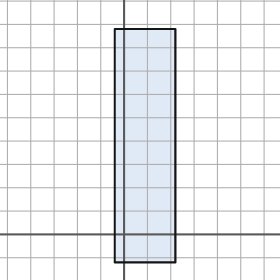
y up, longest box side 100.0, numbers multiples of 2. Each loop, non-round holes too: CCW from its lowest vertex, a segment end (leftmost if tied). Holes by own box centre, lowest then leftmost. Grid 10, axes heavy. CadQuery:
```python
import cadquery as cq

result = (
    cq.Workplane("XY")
    .moveTo(-4.0, -12.0)
    .lineTo(22.0, -12.0)
    .lineTo(22.0, 88.0)
    .lineTo(-4.0, 88.0)
    .close()
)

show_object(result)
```